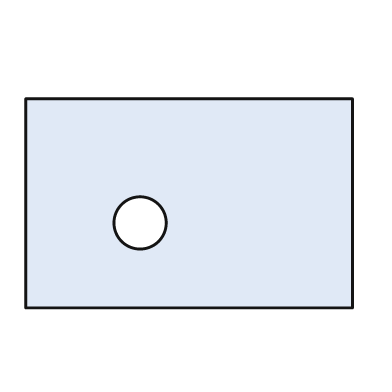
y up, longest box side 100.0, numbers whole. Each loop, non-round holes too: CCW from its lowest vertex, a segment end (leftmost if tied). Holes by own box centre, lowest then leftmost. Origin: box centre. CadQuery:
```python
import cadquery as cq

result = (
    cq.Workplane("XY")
    .moveTo(-50.0, -32.0)
    .lineTo(50.0, -32.0)
    .lineTo(50.0, 32.0)
    .lineTo(-50.0, 32.0)
    .close()
    .moveTo(-15.0, -6.0)
    .circle(8.0)
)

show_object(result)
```